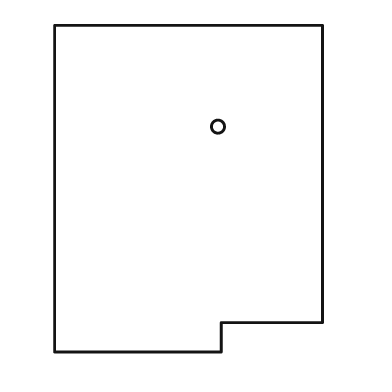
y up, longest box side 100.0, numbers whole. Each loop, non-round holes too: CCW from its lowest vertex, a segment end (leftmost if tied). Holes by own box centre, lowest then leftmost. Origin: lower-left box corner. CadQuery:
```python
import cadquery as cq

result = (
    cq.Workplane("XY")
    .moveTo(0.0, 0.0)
    .lineTo(51.0, 0.0)
    .lineTo(51.0, 9.0)
    .lineTo(82.0, 9.0)
    .lineTo(82.0, 100.0)
    .lineTo(0.0, 100.0)
    .close()
    .moveTo(50.0, 69.0)
    .circle(2.0)
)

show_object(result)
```